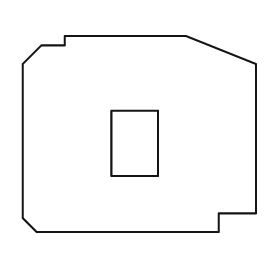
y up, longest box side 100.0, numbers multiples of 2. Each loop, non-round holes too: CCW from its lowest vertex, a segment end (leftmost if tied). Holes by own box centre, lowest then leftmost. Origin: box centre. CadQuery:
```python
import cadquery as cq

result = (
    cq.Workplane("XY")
    .moveTo(-44.0, -42.0)
    .lineTo(34.0, -42.0)
    .lineTo(34.0, -34.0)
    .lineTo(50.0, -34.0)
    .lineTo(50.0, 30.0)
    .lineTo(20.0, 42.0)
    .lineTo(-32.0, 42.0)
    .lineTo(-32.0, 38.0)
    .lineTo(-42.0, 38.0)
    .lineTo(-50.0, 30.0)
    .lineTo(-50.0, -36.0)
    .close()
    .moveTo(-12.0, -18.0)
    .lineTo(8.0, -18.0)
    .lineTo(8.0, 10.0)
    .lineTo(-12.0, 10.0)
    .close()
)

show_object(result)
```